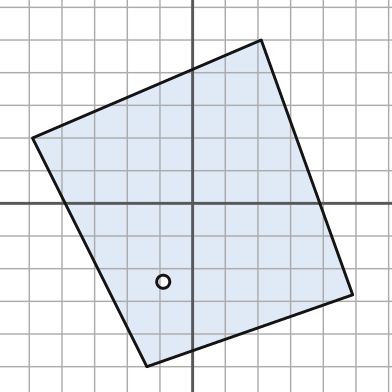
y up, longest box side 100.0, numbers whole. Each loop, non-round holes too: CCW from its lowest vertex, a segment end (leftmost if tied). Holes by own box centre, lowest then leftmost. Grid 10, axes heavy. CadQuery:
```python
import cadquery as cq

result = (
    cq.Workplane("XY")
    .moveTo(-14.0, -50.0)
    .lineTo(49.0, -28.0)
    .lineTo(21.0, 50.0)
    .lineTo(-49.0, 20.0)
    .close()
    .moveTo(-9.0, -24.0)
    .circle(2.0)
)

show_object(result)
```